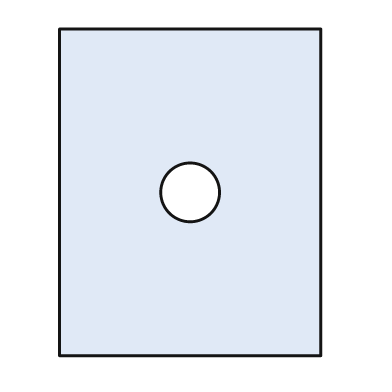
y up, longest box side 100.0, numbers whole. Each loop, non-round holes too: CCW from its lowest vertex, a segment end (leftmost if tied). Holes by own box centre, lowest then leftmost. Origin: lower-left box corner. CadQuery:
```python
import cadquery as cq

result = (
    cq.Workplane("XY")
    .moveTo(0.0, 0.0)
    .lineTo(80.0, 0.0)
    .lineTo(80.0, 100.0)
    .lineTo(0.0, 100.0)
    .close()
    .moveTo(40.0, 50.0)
    .circle(9.0)
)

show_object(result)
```